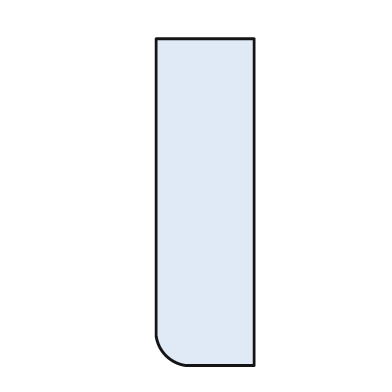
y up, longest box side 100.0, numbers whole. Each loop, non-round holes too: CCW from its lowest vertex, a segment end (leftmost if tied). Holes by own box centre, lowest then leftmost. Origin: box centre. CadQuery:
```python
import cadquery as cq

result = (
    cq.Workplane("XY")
    .moveTo(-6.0, -50.0)
    .lineTo(15.0, -50.0)
    .lineTo(15.0, 50.0)
    .lineTo(-15.0, 50.0)
    .lineTo(-15.0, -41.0)
    .threePointArc((-12.0, -47.0), (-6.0, -50.0))
    .close()
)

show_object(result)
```